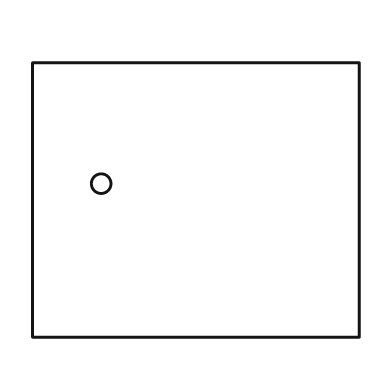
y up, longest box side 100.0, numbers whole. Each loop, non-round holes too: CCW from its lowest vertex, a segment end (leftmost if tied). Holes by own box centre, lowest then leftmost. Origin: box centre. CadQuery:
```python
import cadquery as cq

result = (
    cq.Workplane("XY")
    .moveTo(-50.0, -42.0)
    .lineTo(50.0, -42.0)
    .lineTo(50.0, 42.0)
    .lineTo(-50.0, 42.0)
    .close()
    .moveTo(-29.0, 5.0)
    .circle(3.0)
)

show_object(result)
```